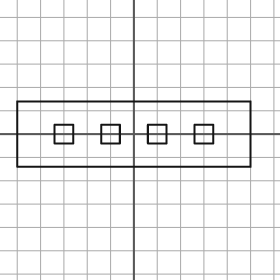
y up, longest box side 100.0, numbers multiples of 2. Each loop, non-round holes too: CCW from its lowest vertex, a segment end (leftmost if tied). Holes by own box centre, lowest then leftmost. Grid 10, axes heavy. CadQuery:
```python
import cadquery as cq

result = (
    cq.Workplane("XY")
    .moveTo(-50.0, -14.0)
    .lineTo(50.0, -14.0)
    .lineTo(50.0, 14.0)
    .lineTo(-50.0, 14.0)
    .close()
    .moveTo(-34.0, -4.0)
    .lineTo(-26.0, -4.0)
    .lineTo(-26.0, 4.0)
    .lineTo(-34.0, 4.0)
    .close()
    .moveTo(-14.0, -4.0)
    .lineTo(-6.0, -4.0)
    .lineTo(-6.0, 4.0)
    .lineTo(-14.0, 4.0)
    .close()
    .moveTo(6.0, -4.0)
    .lineTo(14.0, -4.0)
    .lineTo(14.0, 4.0)
    .lineTo(6.0, 4.0)
    .close()
    .moveTo(26.0, -4.0)
    .lineTo(34.0, -4.0)
    .lineTo(34.0, 4.0)
    .lineTo(26.0, 4.0)
    .close()
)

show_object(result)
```